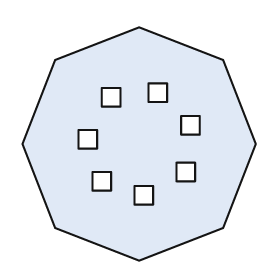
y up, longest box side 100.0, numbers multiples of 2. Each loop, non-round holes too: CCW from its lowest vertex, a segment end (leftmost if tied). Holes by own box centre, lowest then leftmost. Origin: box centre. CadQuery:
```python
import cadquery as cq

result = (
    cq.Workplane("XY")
    .moveTo(0.0, -50.0)
    .lineTo(36.0, -36.0)
    .lineTo(50.0, 0.0)
    .lineTo(36.0, 36.0)
    .lineTo(0.0, 50.0)
    .lineTo(-36.0, 36.0)
    .lineTo(-50.0, 0.0)
    .lineTo(-36.0, -36.0)
    .close()
    .moveTo(-2.0, -26.0)
    .lineTo(6.0, -26.0)
    .lineTo(6.0, -18.0)
    .lineTo(-2.0, -18.0)
    .close()
    .moveTo(-20.0, -20.0)
    .lineTo(-12.0, -20.0)
    .lineTo(-12.0, -12.0)
    .lineTo(-20.0, -12.0)
    .close()
    .moveTo(16.0, -16.0)
    .lineTo(24.0, -16.0)
    .lineTo(24.0, -8.0)
    .lineTo(16.0, -8.0)
    .close()
    .moveTo(-26.0, -2.0)
    .lineTo(-18.0, -2.0)
    .lineTo(-18.0, 6.0)
    .lineTo(-26.0, 6.0)
    .close()
    .moveTo(18.0, 4.0)
    .lineTo(26.0, 4.0)
    .lineTo(26.0, 12.0)
    .lineTo(18.0, 12.0)
    .close()
    .moveTo(-16.0, 16.0)
    .lineTo(-8.0, 16.0)
    .lineTo(-8.0, 24.0)
    .lineTo(-16.0, 24.0)
    .close()
    .moveTo(4.0, 18.0)
    .lineTo(12.0, 18.0)
    .lineTo(12.0, 26.0)
    .lineTo(4.0, 26.0)
    .close()
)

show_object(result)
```